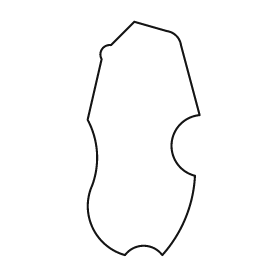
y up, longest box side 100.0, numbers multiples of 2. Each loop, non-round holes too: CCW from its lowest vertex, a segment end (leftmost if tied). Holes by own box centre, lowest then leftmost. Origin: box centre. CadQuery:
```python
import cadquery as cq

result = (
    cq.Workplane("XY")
    .moveTo(-8.0, -50.0)
    .threePointArc((0.0, -46.0), (8.0, -50.0))
    .threePointArc((18.0, -34.0), (22.0, -16.0))
    .threePointArc((12.0, -2.0), (24.0, 10.0))
    .lineTo(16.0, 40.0)
    .threePointArc((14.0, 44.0), (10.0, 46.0))
    .lineTo(-4.0, 50.0)
    .lineTo(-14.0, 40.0)
    .threePointArc((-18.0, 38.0), (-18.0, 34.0))
    .lineTo(-24.0, 8.0)
    .threePointArc((-20.0, -6.0), (-22.0, -20.0))
    .threePointArc((-22.0, -38.0), (-8.0, -50.0))
    .close()
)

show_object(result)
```